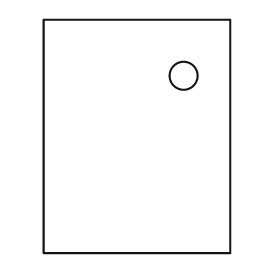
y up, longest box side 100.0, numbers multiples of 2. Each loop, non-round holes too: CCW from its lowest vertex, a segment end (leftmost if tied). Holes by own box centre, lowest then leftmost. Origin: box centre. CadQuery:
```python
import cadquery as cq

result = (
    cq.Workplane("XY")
    .moveTo(-40.0, -50.0)
    .lineTo(40.0, -50.0)
    .lineTo(40.0, 50.0)
    .lineTo(-40.0, 50.0)
    .close()
    .moveTo(20.0, 26.0)
    .circle(6.0)
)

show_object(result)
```